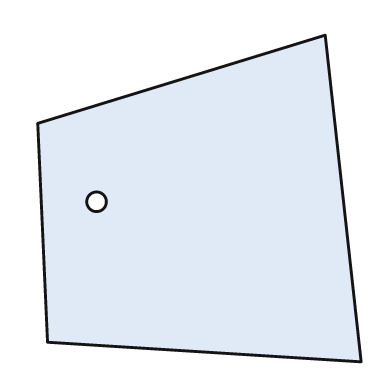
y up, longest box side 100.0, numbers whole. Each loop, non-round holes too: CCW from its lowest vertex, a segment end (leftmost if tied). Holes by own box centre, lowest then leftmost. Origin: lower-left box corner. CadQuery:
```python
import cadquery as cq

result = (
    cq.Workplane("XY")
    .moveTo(99.0, 0.0)
    .lineTo(88.0, 100.0)
    .lineTo(0.0, 73.0)
    .lineTo(3.0, 6.0)
    .close()
    .moveTo(18.0, 49.0)
    .circle(3.0)
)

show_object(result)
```